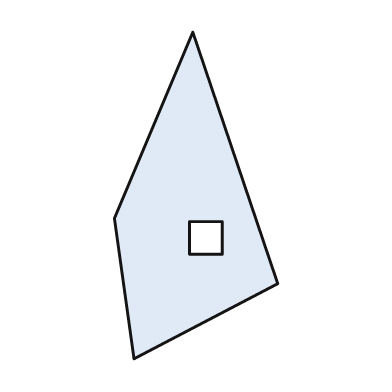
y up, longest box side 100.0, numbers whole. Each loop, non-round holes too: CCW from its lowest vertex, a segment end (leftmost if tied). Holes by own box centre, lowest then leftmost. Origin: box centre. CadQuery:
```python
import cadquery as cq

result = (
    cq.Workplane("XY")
    .moveTo(-19.0, -50.0)
    .lineTo(25.0, -27.0)
    .lineTo(-1.0, 50.0)
    .lineTo(-25.0, -7.0)
    .close()
    .moveTo(-2.0, -18.0)
    .lineTo(8.0, -18.0)
    .lineTo(8.0, -8.0)
    .lineTo(-2.0, -8.0)
    .close()
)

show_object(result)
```